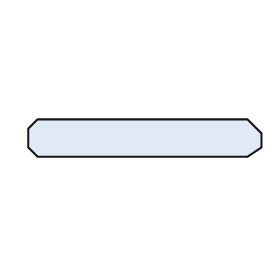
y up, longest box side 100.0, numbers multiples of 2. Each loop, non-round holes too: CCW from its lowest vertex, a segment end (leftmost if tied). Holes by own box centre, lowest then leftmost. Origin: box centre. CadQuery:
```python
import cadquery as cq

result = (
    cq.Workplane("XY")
    .moveTo(-46.0, -8.0)
    .lineTo(44.0, -8.0)
    .lineTo(50.0, -4.0)
    .lineTo(50.0, 2.0)
    .lineTo(44.0, 8.0)
    .lineTo(-46.0, 8.0)
    .lineTo(-50.0, 4.0)
    .lineTo(-50.0, -4.0)
    .close()
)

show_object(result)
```